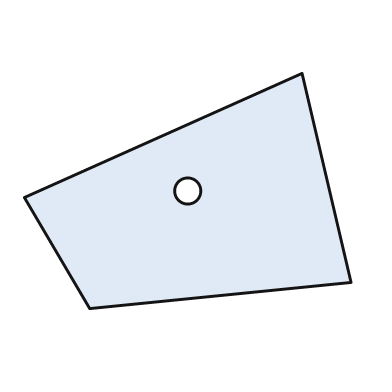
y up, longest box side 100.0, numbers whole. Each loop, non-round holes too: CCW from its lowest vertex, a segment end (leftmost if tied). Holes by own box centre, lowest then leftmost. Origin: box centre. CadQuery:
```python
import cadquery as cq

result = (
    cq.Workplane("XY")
    .moveTo(-30.0, -36.0)
    .lineTo(50.0, -28.0)
    .lineTo(35.0, 36.0)
    .lineTo(-50.0, -2.0)
    .close()
    .moveTo(0.0, 0.0)
    .circle(4.0)
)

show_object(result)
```